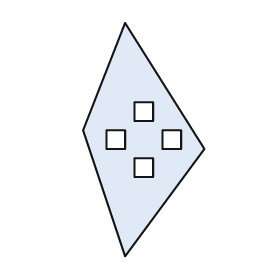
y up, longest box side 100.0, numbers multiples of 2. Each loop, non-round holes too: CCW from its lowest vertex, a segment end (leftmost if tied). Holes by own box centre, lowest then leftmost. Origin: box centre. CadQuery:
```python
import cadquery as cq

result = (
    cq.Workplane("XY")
    .moveTo(-8.0, -50.0)
    .lineTo(26.0, -4.0)
    .lineTo(-8.0, 50.0)
    .lineTo(-26.0, 4.0)
    .close()
    .moveTo(-4.0, -16.0)
    .lineTo(4.0, -16.0)
    .lineTo(4.0, -8.0)
    .lineTo(-4.0, -8.0)
    .close()
    .moveTo(-16.0, -4.0)
    .lineTo(-8.0, -4.0)
    .lineTo(-8.0, 4.0)
    .lineTo(-16.0, 4.0)
    .close()
    .moveTo(8.0, -4.0)
    .lineTo(16.0, -4.0)
    .lineTo(16.0, 4.0)
    .lineTo(8.0, 4.0)
    .close()
    .moveTo(-4.0, 8.0)
    .lineTo(4.0, 8.0)
    .lineTo(4.0, 16.0)
    .lineTo(-4.0, 16.0)
    .close()
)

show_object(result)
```